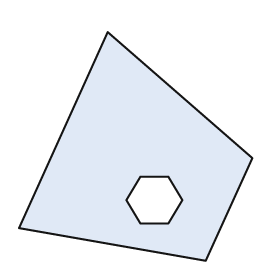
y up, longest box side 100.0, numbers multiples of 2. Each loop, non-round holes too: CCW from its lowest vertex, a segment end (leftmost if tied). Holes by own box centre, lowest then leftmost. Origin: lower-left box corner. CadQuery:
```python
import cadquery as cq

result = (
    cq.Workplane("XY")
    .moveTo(80.0, 0.0)
    .lineTo(100.0, 44.0)
    .lineTo(38.0, 98.0)
    .lineTo(0.0, 14.0)
    .close()
    .moveTo(52.0, 16.0)
    .lineTo(64.0, 16.0)
    .lineTo(70.0, 26.0)
    .lineTo(64.0, 36.0)
    .lineTo(52.0, 36.0)
    .lineTo(46.0, 26.0)
    .close()
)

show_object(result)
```